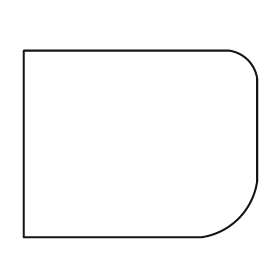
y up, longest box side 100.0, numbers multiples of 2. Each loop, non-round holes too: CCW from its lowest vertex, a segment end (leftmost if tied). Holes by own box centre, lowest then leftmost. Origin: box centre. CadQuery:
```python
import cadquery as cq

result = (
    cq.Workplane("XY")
    .moveTo(-50.0, -40.0)
    .lineTo(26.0, -40.0)
    .threePointArc((42.0, -32.0), (50.0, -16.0))
    .lineTo(50.0, 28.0)
    .threePointArc((46.0, 36.0), (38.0, 40.0))
    .lineTo(-50.0, 40.0)
    .close()
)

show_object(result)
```